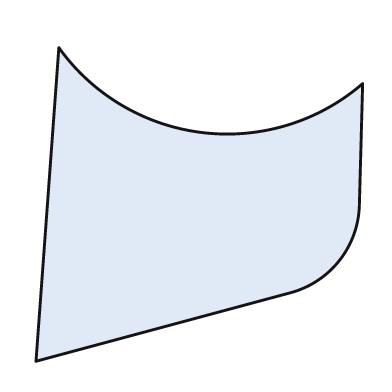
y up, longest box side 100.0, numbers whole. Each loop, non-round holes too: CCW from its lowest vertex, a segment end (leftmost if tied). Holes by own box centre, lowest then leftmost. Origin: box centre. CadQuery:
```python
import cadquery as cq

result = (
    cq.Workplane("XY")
    .moveTo(-50.0, -48.0)
    .lineTo(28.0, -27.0)
    .threePointArc((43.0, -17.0), (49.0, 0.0))
    .lineTo(50.0, 37.0)
    .threePointArc((1.0, 22.0), (-43.0, 48.0))
    .close()
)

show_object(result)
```